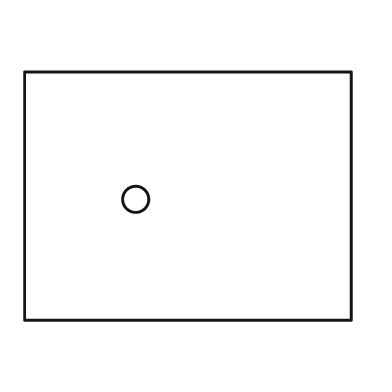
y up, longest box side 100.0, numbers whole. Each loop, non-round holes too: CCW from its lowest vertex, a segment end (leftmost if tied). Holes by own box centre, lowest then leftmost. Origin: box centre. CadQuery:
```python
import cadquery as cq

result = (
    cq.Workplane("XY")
    .moveTo(-50.0, -38.0)
    .lineTo(50.0, -38.0)
    .lineTo(50.0, 38.0)
    .lineTo(-50.0, 38.0)
    .close()
    .moveTo(-16.0, -1.0)
    .circle(4.0)
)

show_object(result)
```